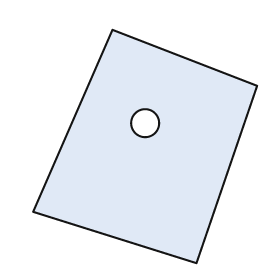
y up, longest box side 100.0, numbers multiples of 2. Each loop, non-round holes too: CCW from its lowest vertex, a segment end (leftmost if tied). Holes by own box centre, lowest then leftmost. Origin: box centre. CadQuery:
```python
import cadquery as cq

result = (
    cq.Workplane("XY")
    .moveTo(22.0, -50.0)
    .lineTo(48.0, 26.0)
    .lineTo(-14.0, 50.0)
    .lineTo(-48.0, -28.0)
    .close()
    .moveTo(0.0, 10.0)
    .circle(6.0)
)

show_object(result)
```